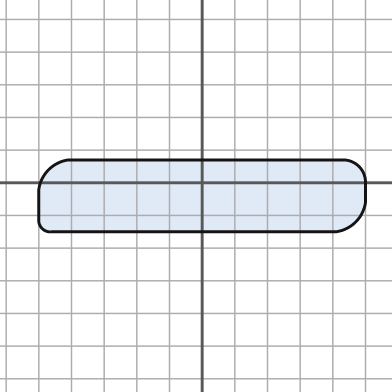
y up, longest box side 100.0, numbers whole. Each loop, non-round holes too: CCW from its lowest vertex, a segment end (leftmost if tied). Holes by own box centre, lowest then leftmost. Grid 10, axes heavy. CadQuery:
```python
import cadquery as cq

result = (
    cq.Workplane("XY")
    .moveTo(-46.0, -15.0)
    .lineTo(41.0, -15.0)
    .threePointArc((47.0, -12.0), (50.0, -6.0))
    .lineTo(50.0, 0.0)
    .threePointArc((48.0, 5.0), (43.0, 7.0))
    .lineTo(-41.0, 7.0)
    .threePointArc((-47.0, 4.0), (-50.0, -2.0))
    .lineTo(-50.0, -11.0)
    .threePointArc((-49.0, -14.0), (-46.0, -15.0))
    .close()
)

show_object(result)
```